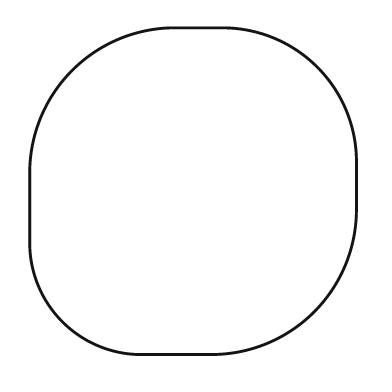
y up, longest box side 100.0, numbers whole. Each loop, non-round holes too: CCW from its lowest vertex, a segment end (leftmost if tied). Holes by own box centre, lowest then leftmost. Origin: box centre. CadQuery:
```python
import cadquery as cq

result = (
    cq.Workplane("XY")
    .moveTo(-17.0, -50.0)
    .lineTo(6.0, -50.0)
    .threePointArc((37.0, -37.0), (50.0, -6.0))
    .lineTo(50.0, 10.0)
    .threePointArc((38.0, 38.0), (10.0, 50.0))
    .lineTo(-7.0, 50.0)
    .threePointArc((-37.0, 37.0), (-50.0, 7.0))
    .lineTo(-50.0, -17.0)
    .threePointArc((-40.0, -40.0), (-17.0, -50.0))
    .close()
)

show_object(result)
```